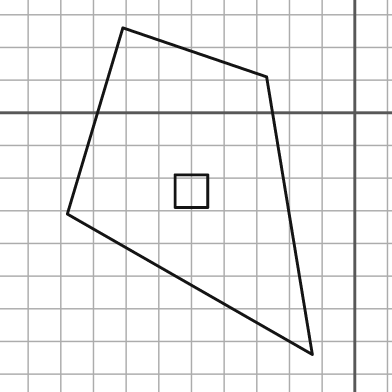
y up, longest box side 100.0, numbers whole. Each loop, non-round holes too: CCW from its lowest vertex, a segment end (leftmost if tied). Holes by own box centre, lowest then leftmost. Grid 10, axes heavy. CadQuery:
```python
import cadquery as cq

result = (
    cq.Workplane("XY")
    .moveTo(-13.0, -74.0)
    .lineTo(-27.0, 11.0)
    .lineTo(-71.0, 26.0)
    .lineTo(-88.0, -31.0)
    .close()
    .moveTo(-55.0, -29.0)
    .lineTo(-45.0, -29.0)
    .lineTo(-45.0, -19.0)
    .lineTo(-55.0, -19.0)
    .close()
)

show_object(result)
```